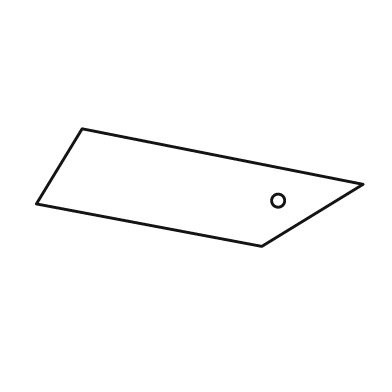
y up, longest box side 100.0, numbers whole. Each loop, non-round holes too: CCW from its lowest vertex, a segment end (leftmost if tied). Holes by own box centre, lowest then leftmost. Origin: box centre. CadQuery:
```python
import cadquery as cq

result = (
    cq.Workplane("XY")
    .moveTo(19.0, -18.0)
    .lineTo(50.0, 1.0)
    .lineTo(-36.0, 18.0)
    .lineTo(-50.0, -5.0)
    .close()
    .moveTo(24.0, -4.0)
    .circle(2.0)
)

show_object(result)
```